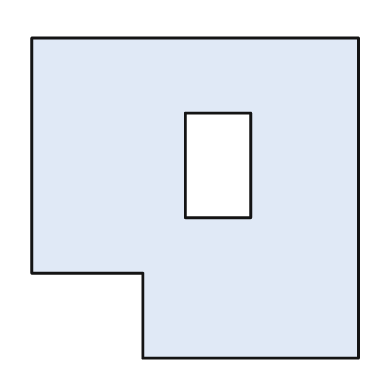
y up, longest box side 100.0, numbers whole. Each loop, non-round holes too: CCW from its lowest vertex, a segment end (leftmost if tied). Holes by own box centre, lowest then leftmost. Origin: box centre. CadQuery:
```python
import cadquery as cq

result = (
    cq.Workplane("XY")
    .moveTo(-16.0, -49.0)
    .lineTo(50.0, -49.0)
    .lineTo(50.0, 49.0)
    .lineTo(-50.0, 49.0)
    .lineTo(-50.0, -23.0)
    .lineTo(-16.0, -23.0)
    .close()
    .moveTo(-3.0, -6.0)
    .lineTo(17.0, -6.0)
    .lineTo(17.0, 26.0)
    .lineTo(-3.0, 26.0)
    .close()
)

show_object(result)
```